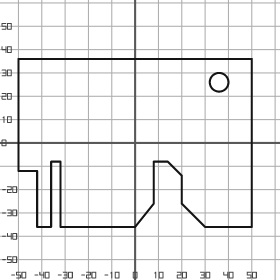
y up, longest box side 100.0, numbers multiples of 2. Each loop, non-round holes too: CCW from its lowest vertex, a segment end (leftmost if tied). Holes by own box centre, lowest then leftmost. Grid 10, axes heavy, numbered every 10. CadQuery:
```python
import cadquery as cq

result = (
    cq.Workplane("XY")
    .moveTo(-42.0, -36.0)
    .lineTo(-36.0, -36.0)
    .lineTo(-36.0, -8.0)
    .lineTo(-32.0, -8.0)
    .lineTo(-32.0, -36.0)
    .lineTo(0.0, -36.0)
    .lineTo(8.0, -26.0)
    .lineTo(8.0, -8.0)
    .lineTo(14.0, -8.0)
    .lineTo(20.0, -14.0)
    .lineTo(20.0, -26.0)
    .lineTo(30.0, -36.0)
    .lineTo(50.0, -36.0)
    .lineTo(50.0, 36.0)
    .lineTo(-50.0, 36.0)
    .lineTo(-50.0, -12.0)
    .lineTo(-42.0, -12.0)
    .close()
    .moveTo(36.0, 26.0)
    .circle(4.0)
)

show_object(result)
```